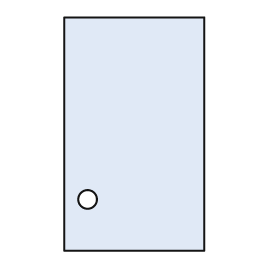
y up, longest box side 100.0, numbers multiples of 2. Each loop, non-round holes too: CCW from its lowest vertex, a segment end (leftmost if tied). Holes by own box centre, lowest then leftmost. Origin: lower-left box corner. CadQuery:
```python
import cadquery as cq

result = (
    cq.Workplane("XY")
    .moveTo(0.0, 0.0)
    .lineTo(60.0, 0.0)
    .lineTo(60.0, 100.0)
    .lineTo(0.0, 100.0)
    .close()
    .moveTo(10.0, 22.0)
    .circle(4.0)
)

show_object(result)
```